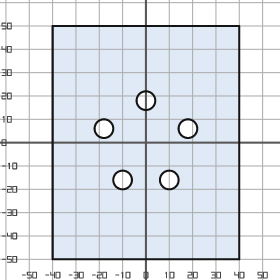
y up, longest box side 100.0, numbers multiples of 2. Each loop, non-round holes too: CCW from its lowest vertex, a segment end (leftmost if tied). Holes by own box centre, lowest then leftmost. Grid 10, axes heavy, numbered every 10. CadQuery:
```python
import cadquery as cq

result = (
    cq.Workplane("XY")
    .moveTo(-40.0, -50.0)
    .lineTo(40.0, -50.0)
    .lineTo(40.0, 50.0)
    .lineTo(-40.0, 50.0)
    .close()
    .moveTo(-10.0, -16.0)
    .circle(4.0)
    .moveTo(10.0, -16.0)
    .circle(4.0)
    .moveTo(-18.0, 6.0)
    .circle(4.0)
    .moveTo(18.0, 6.0)
    .circle(4.0)
    .moveTo(0.0, 18.0)
    .circle(4.0)
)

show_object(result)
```